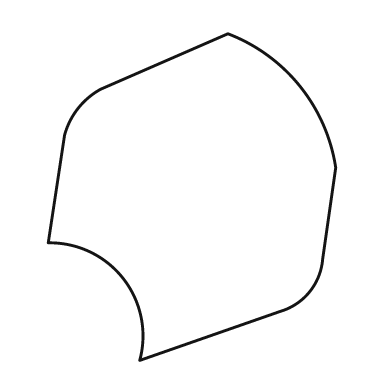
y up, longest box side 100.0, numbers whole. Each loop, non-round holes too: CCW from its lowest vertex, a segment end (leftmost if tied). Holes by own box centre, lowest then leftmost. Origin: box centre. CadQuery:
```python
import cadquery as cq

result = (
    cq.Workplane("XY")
    .moveTo(-16.0, -50.0)
    .lineTo(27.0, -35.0)
    .threePointArc((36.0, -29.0), (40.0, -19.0))
    .lineTo(44.0, 9.0)
    .threePointArc((33.0, 34.0), (11.0, 50.0))
    .lineTo(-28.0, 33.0)
    .threePointArc((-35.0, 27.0), (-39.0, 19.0))
    .lineTo(-44.0, -14.0)
    .threePointArc((-21.0, -25.0), (-16.0, -50.0))
    .close()
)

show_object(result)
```